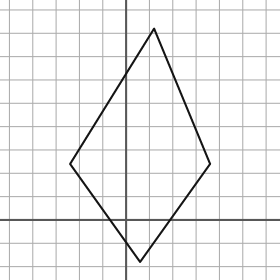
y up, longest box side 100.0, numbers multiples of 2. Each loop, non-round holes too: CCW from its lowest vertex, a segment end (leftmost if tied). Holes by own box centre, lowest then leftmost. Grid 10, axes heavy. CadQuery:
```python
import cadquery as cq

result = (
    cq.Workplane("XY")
    .moveTo(6.0, -18.0)
    .lineTo(36.0, 24.0)
    .lineTo(12.0, 82.0)
    .lineTo(-24.0, 24.0)
    .close()
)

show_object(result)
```